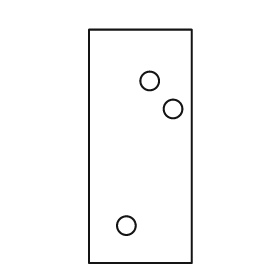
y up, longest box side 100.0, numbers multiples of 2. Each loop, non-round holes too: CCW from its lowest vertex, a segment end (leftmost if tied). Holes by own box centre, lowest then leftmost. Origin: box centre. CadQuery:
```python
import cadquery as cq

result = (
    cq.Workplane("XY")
    .moveTo(-22.0, -50.0)
    .lineTo(22.0, -50.0)
    .lineTo(22.0, 50.0)
    .lineTo(-22.0, 50.0)
    .close()
    .moveTo(-6.0, -34.0)
    .circle(4.0)
    .moveTo(14.0, 16.0)
    .circle(4.0)
    .moveTo(4.0, 28.0)
    .circle(4.0)
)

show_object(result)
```